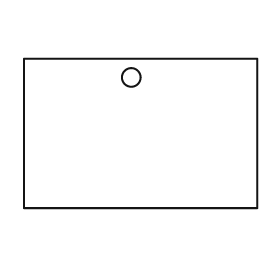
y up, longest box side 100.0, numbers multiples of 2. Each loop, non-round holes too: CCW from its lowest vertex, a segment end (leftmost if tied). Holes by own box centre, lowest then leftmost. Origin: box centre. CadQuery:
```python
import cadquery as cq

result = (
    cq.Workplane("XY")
    .moveTo(-50.0, -32.0)
    .lineTo(50.0, -32.0)
    .lineTo(50.0, 32.0)
    .lineTo(-50.0, 32.0)
    .close()
    .moveTo(-4.0, 24.0)
    .circle(4.0)
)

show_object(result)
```